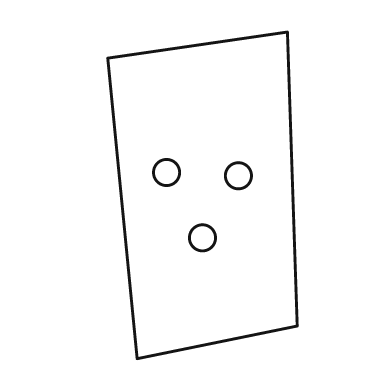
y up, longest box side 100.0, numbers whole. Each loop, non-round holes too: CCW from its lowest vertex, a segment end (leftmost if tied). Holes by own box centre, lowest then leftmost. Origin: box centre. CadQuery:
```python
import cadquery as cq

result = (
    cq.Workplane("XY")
    .moveTo(-20.0, -50.0)
    .lineTo(29.0, -40.0)
    .lineTo(26.0, 50.0)
    .lineTo(-29.0, 42.0)
    .close()
    .moveTo(0.0, -13.0)
    .circle(4.0)
    .moveTo(11.0, 6.0)
    .circle(4.0)
    .moveTo(-11.0, 7.0)
    .circle(4.0)
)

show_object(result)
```